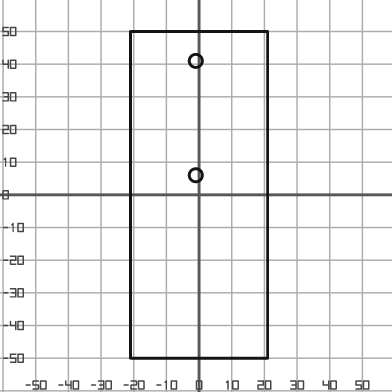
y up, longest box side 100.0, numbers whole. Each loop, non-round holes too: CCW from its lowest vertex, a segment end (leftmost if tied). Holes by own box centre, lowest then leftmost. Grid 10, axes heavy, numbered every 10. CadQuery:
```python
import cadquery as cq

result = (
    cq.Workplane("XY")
    .moveTo(-21.0, -50.0)
    .lineTo(21.0, -50.0)
    .lineTo(21.0, 50.0)
    .lineTo(-21.0, 50.0)
    .close()
    .moveTo(-1.0, 6.0)
    .circle(2.0)
    .moveTo(-1.0, 41.0)
    .circle(2.0)
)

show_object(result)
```